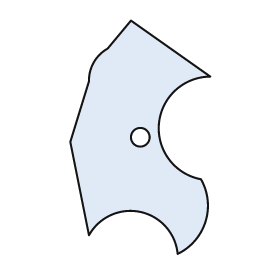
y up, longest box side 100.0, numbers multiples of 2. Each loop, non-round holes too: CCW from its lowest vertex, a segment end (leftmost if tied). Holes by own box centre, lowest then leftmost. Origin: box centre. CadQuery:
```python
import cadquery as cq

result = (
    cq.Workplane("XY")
    .moveTo(16.0, -50.0)
    .threePointArc((28.0, -36.0), (26.0, -18.0))
    .threePointArc((8.0, 6.0), (30.0, 26.0))
    .lineTo(-4.0, 50.0)
    .lineTo(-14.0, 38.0)
    .threePointArc((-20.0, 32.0), (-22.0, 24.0))
    .lineTo(-30.0, -2.0)
    .lineTo(-22.0, -42.0)
    .threePointArc((0.0, -32.0), (16.0, -50.0))
    .close()
    .moveTo(0.0, 0.0)
    .circle(4.0)
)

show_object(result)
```